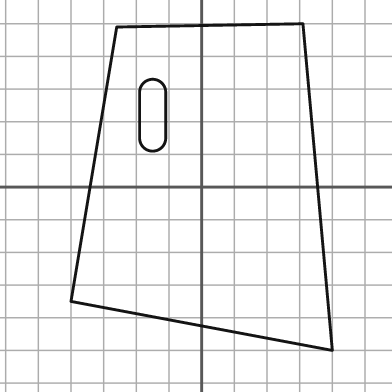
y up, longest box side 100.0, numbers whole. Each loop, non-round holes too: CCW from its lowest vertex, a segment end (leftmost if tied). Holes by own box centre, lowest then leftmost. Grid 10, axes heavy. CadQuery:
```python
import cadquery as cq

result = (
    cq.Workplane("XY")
    .moveTo(40.0, -50.0)
    .lineTo(31.0, 50.0)
    .lineTo(-26.0, 49.0)
    .lineTo(-40.0, -35.0)
    .close()
    .moveTo(-19.0, 15.0)
    .threePointArc((-15.0, 11.0), (-11.0, 15.0))
    .lineTo(-11.0, 29.0)
    .threePointArc((-15.0, 33.0), (-19.0, 29.0))
    .close()
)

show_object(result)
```